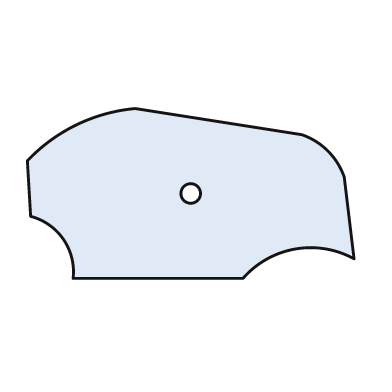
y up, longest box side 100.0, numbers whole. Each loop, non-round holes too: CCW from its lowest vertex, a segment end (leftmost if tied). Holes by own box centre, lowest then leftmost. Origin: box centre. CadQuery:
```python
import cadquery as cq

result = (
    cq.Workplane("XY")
    .moveTo(-36.0, -26.0)
    .lineTo(16.0, -26.0)
    .threePointArc((32.0, -17.0), (50.0, -20.0))
    .lineTo(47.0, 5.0)
    .threePointArc((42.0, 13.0), (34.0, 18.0))
    .lineTo(-17.0, 26.0)
    .threePointArc((-35.0, 21.0), (-50.0, 10.0))
    .lineTo(-49.0, -7.0)
    .threePointArc((-39.0, -14.0), (-36.0, -26.0))
    .close()
    .moveTo(0.0, 0.0)
    .circle(3.0)
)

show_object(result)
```